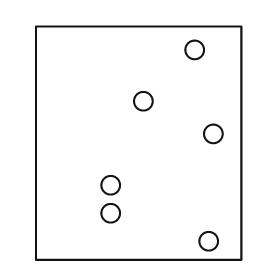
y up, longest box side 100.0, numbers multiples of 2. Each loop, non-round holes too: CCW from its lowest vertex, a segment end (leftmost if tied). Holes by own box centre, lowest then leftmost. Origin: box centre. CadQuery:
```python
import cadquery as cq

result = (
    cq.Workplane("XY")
    .moveTo(-44.0, -50.0)
    .lineTo(44.0, -50.0)
    .lineTo(44.0, 50.0)
    .lineTo(-44.0, 50.0)
    .close()
    .moveTo(30.0, -42.0)
    .circle(4.0)
    .moveTo(-12.0, -30.0)
    .circle(4.0)
    .moveTo(-12.0, -18.0)
    .circle(4.0)
    .moveTo(32.0, 4.0)
    .circle(4.0)
    .moveTo(2.0, 18.0)
    .circle(4.0)
    .moveTo(24.0, 40.0)
    .circle(4.0)
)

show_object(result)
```